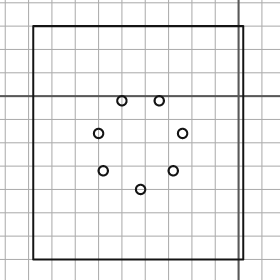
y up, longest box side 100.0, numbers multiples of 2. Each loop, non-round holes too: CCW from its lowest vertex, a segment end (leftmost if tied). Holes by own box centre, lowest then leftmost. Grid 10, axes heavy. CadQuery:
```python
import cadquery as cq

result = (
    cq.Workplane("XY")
    .moveTo(-88.0, -70.0)
    .lineTo(2.0, -70.0)
    .lineTo(2.0, 30.0)
    .lineTo(-88.0, 30.0)
    .close()
    .moveTo(-42.0, -40.0)
    .circle(2.0)
    .moveTo(-58.0, -32.0)
    .circle(2.0)
    .moveTo(-28.0, -32.0)
    .circle(2.0)
    .moveTo(-60.0, -16.0)
    .circle(2.0)
    .moveTo(-24.0, -16.0)
    .circle(2.0)
    .moveTo(-50.0, -2.0)
    .circle(2.0)
    .moveTo(-34.0, -2.0)
    .circle(2.0)
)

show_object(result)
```